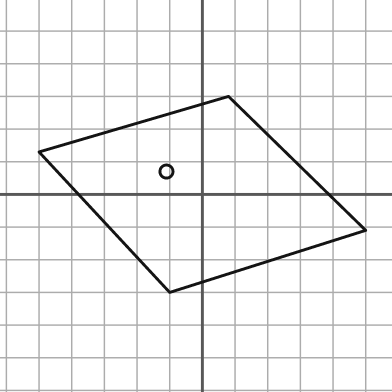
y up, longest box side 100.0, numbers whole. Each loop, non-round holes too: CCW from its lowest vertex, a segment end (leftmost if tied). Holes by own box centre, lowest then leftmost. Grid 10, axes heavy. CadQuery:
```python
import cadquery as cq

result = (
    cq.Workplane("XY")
    .moveTo(-10.0, -30.0)
    .lineTo(50.0, -11.0)
    .lineTo(8.0, 30.0)
    .lineTo(-50.0, 13.0)
    .close()
    .moveTo(-11.0, 7.0)
    .circle(2.0)
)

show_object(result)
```